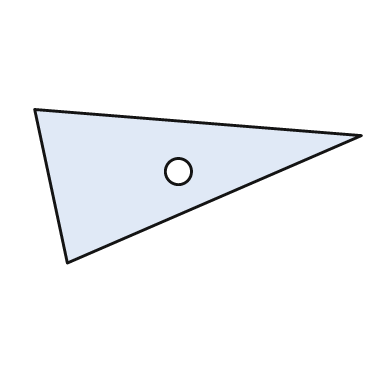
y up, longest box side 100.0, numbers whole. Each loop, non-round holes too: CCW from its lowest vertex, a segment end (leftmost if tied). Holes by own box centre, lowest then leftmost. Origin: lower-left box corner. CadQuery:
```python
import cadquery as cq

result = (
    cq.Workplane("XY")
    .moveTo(10.0, 0.0)
    .lineTo(100.0, 39.0)
    .lineTo(0.0, 47.0)
    .close()
    .moveTo(44.0, 28.0)
    .circle(4.0)
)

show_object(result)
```